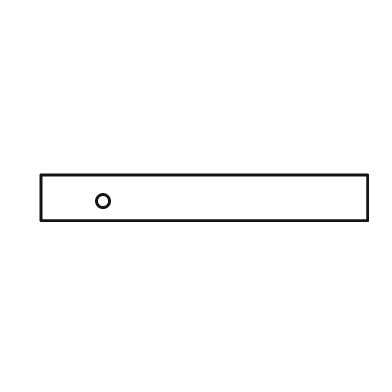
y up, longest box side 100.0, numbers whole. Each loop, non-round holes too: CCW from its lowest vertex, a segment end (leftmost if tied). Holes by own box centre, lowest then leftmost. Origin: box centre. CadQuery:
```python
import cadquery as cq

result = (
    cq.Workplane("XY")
    .moveTo(-50.0, -7.0)
    .lineTo(50.0, -7.0)
    .lineTo(50.0, 7.0)
    .lineTo(-50.0, 7.0)
    .close()
    .moveTo(-31.0, -1.0)
    .circle(2.0)
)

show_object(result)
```